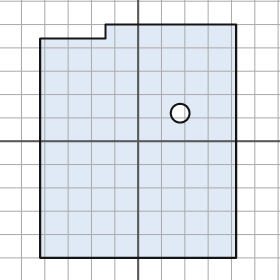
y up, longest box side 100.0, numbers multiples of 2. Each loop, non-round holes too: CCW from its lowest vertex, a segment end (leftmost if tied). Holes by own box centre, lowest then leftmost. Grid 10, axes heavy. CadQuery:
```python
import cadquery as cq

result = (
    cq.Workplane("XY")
    .moveTo(-42.0, -50.0)
    .lineTo(42.0, -50.0)
    .lineTo(42.0, 50.0)
    .lineTo(-14.0, 50.0)
    .lineTo(-14.0, 44.0)
    .lineTo(-42.0, 44.0)
    .close()
    .moveTo(18.0, 12.0)
    .circle(4.0)
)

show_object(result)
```